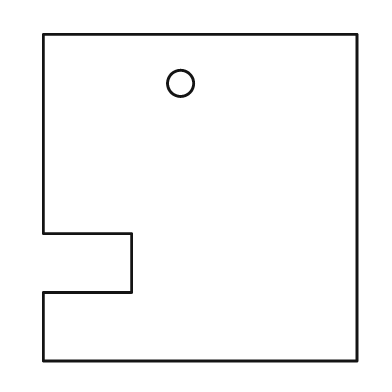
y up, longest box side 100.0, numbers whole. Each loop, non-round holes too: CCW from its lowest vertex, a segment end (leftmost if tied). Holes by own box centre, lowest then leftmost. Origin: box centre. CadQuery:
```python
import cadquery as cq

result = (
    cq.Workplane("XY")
    .moveTo(-48.0, -50.0)
    .lineTo(48.0, -50.0)
    .lineTo(48.0, 50.0)
    .lineTo(-48.0, 50.0)
    .lineTo(-48.0, -11.0)
    .lineTo(-21.0, -11.0)
    .lineTo(-21.0, -29.0)
    .lineTo(-48.0, -29.0)
    .close()
    .moveTo(-6.0, 35.0)
    .circle(4.0)
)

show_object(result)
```